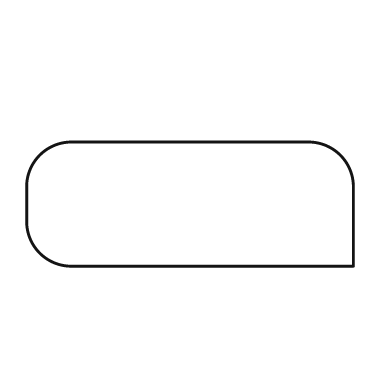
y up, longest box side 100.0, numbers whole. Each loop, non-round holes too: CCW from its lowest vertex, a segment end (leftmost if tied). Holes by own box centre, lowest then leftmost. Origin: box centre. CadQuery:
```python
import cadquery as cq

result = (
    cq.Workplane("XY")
    .moveTo(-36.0, -19.0)
    .lineTo(50.0, -19.0)
    .lineTo(50.0, 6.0)
    .threePointArc((46.0, 15.0), (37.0, 19.0))
    .lineTo(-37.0, 19.0)
    .threePointArc((-46.0, 15.0), (-50.0, 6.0))
    .lineTo(-50.0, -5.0)
    .threePointArc((-46.0, -15.0), (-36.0, -19.0))
    .close()
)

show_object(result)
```